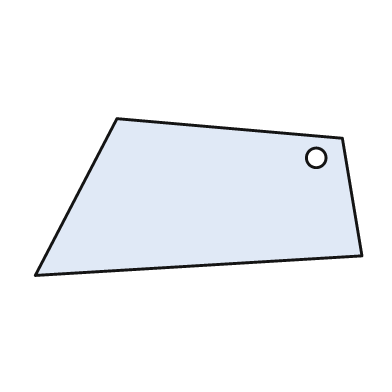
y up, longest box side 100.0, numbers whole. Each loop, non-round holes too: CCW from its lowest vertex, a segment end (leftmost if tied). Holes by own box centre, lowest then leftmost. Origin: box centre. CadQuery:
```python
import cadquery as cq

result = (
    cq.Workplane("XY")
    .moveTo(-50.0, -24.0)
    .lineTo(50.0, -18.0)
    .lineTo(44.0, 18.0)
    .lineTo(-25.0, 24.0)
    .close()
    .moveTo(36.0, 12.0)
    .circle(3.0)
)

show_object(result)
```